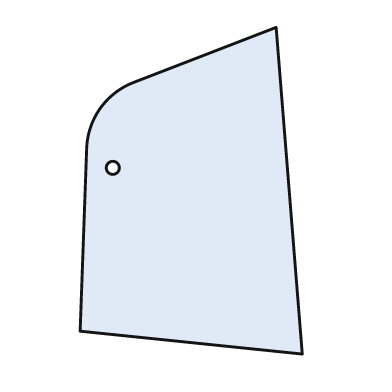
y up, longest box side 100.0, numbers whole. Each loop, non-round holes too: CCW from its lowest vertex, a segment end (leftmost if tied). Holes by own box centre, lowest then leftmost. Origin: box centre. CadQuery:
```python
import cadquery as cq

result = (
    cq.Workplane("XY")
    .moveTo(34.0, -50.0)
    .lineTo(26.0, 50.0)
    .lineTo(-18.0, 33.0)
    .threePointArc((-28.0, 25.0), (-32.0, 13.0))
    .lineTo(-34.0, -43.0)
    .close()
    .moveTo(-24.0, 7.0)
    .circle(2.0)
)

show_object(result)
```